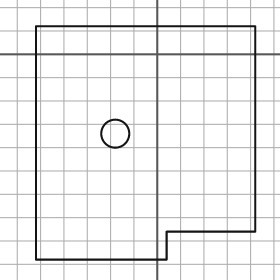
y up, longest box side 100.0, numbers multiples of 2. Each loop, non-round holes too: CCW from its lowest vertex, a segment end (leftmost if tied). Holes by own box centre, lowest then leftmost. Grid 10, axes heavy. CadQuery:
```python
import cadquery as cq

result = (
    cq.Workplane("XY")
    .moveTo(-52.0, -88.0)
    .lineTo(4.0, -88.0)
    .lineTo(4.0, -76.0)
    .lineTo(42.0, -76.0)
    .lineTo(42.0, 12.0)
    .lineTo(-52.0, 12.0)
    .close()
    .moveTo(-18.0, -34.0)
    .circle(6.0)
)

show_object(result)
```